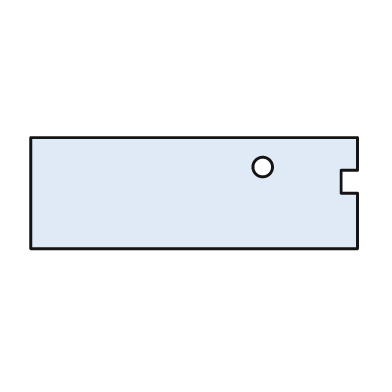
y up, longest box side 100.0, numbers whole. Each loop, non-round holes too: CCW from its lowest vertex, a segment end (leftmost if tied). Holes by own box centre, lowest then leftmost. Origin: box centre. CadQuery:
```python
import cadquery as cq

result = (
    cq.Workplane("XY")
    .moveTo(-50.0, -17.0)
    .lineTo(50.0, -17.0)
    .lineTo(50.0, 0.0)
    .lineTo(45.0, 0.0)
    .lineTo(45.0, 7.0)
    .lineTo(50.0, 7.0)
    .lineTo(50.0, 17.0)
    .lineTo(-50.0, 17.0)
    .close()
    .moveTo(21.0, 8.0)
    .circle(3.0)
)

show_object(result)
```